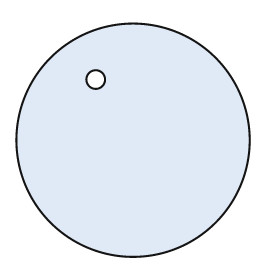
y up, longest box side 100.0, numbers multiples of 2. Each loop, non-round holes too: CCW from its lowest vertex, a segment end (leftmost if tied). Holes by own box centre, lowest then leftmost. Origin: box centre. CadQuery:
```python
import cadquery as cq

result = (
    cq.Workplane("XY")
    .moveTo(0.0, 0.0)
    .circle(50.0)
    .moveTo(-16.0, 26.0)
    .circle(4.0)
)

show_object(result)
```